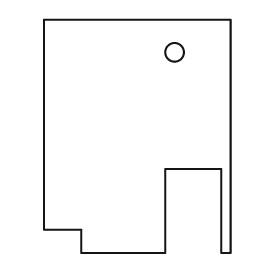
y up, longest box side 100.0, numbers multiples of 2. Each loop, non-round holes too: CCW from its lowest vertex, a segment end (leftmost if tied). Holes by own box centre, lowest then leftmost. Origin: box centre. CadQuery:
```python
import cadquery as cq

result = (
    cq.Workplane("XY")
    .moveTo(-24.0, -50.0)
    .lineTo(12.0, -50.0)
    .lineTo(12.0, -14.0)
    .lineTo(36.0, -14.0)
    .lineTo(36.0, -50.0)
    .lineTo(40.0, -50.0)
    .lineTo(40.0, 50.0)
    .lineTo(-40.0, 50.0)
    .lineTo(-40.0, -40.0)
    .lineTo(-24.0, -40.0)
    .close()
    .moveTo(16.0, 36.0)
    .circle(4.0)
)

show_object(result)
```